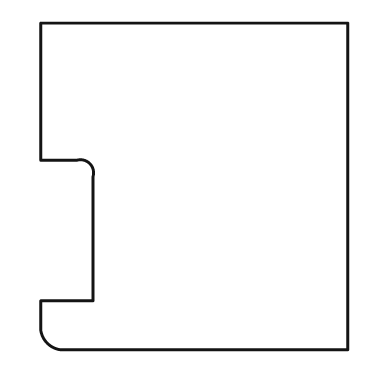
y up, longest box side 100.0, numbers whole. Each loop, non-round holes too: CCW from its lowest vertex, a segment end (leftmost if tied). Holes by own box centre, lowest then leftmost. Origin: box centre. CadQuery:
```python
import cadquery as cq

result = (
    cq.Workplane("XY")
    .moveTo(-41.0, -50.0)
    .lineTo(47.0, -50.0)
    .lineTo(47.0, 50.0)
    .lineTo(-47.0, 50.0)
    .lineTo(-47.0, 8.0)
    .lineTo(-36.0, 8.0)
    .threePointArc((-32.0, 7.0), (-31.0, 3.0))
    .lineTo(-31.0, -35.0)
    .lineTo(-47.0, -35.0)
    .lineTo(-47.0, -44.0)
    .threePointArc((-45.0, -48.0), (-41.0, -50.0))
    .close()
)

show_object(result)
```